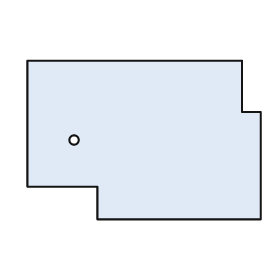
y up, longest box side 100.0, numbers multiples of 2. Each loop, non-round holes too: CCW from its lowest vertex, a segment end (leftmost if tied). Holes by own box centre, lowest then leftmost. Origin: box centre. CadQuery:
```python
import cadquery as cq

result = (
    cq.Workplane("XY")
    .moveTo(-20.0, -34.0)
    .lineTo(50.0, -34.0)
    .lineTo(50.0, 12.0)
    .lineTo(42.0, 12.0)
    .lineTo(42.0, 34.0)
    .lineTo(-50.0, 34.0)
    .lineTo(-50.0, -20.0)
    .lineTo(-20.0, -20.0)
    .close()
    .moveTo(-30.0, 0.0)
    .circle(2.0)
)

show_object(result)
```